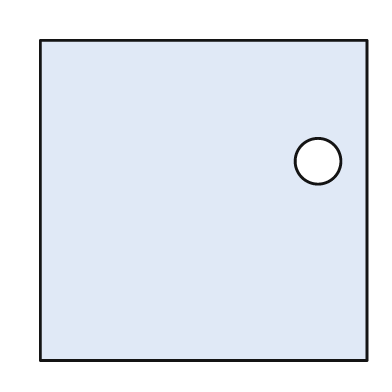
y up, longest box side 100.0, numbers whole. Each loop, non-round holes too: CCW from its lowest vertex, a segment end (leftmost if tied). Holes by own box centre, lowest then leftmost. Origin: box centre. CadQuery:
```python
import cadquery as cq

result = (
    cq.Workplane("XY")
    .moveTo(-50.0, -49.0)
    .lineTo(50.0, -49.0)
    .lineTo(50.0, 49.0)
    .lineTo(-50.0, 49.0)
    .close()
    .moveTo(35.0, 12.0)
    .circle(7.0)
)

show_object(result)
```